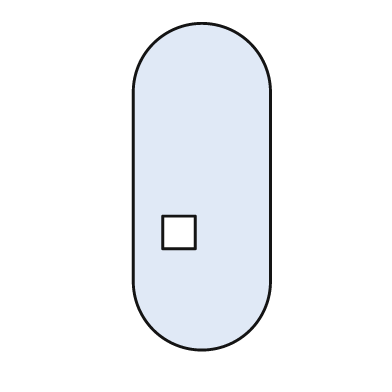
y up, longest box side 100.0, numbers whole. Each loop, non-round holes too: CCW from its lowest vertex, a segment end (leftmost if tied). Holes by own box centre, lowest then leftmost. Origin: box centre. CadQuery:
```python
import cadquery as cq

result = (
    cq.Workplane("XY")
    .moveTo(-21.0, -29.0)
    .threePointArc((0.0, -50.0), (21.0, -29.0))
    .lineTo(21.0, 29.0)
    .threePointArc((0.0, 50.0), (-21.0, 29.0))
    .close()
    .moveTo(-12.0, -19.0)
    .lineTo(-2.0, -19.0)
    .lineTo(-2.0, -9.0)
    .lineTo(-12.0, -9.0)
    .close()
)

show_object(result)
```